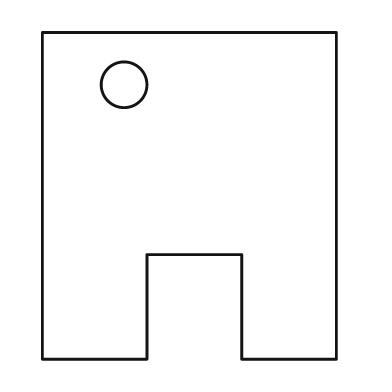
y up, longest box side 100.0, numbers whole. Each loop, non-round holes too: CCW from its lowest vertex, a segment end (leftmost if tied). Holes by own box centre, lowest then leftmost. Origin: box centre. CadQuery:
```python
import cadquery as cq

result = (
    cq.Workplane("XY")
    .moveTo(-45.0, -50.0)
    .lineTo(-13.0, -50.0)
    .lineTo(-13.0, -18.0)
    .lineTo(16.0, -18.0)
    .lineTo(16.0, -50.0)
    .lineTo(45.0, -50.0)
    .lineTo(45.0, 50.0)
    .lineTo(-45.0, 50.0)
    .close()
    .moveTo(-20.0, 34.0)
    .circle(7.0)
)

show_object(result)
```